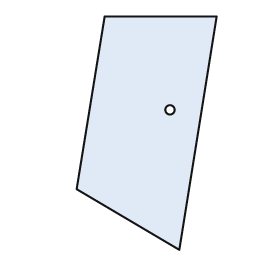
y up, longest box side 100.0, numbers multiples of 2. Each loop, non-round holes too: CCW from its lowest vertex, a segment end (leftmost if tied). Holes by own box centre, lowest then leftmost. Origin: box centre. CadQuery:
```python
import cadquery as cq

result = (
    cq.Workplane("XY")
    .moveTo(14.0, -50.0)
    .lineTo(30.0, 50.0)
    .lineTo(-18.0, 50.0)
    .lineTo(-30.0, -24.0)
    .close()
    .moveTo(10.0, 10.0)
    .circle(2.0)
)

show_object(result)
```